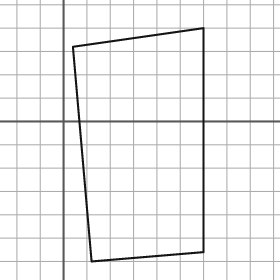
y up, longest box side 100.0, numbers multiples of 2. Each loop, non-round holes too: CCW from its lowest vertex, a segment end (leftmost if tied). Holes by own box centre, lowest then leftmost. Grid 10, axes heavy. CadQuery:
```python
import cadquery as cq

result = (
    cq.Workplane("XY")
    .moveTo(12.0, -60.0)
    .lineTo(60.0, -56.0)
    .lineTo(60.0, 40.0)
    .lineTo(4.0, 32.0)
    .close()
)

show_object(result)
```